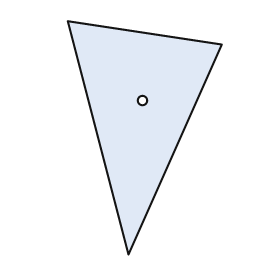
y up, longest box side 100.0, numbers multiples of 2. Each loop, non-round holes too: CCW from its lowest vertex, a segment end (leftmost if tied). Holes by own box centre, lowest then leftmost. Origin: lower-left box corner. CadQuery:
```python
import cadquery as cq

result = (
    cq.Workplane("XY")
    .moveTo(26.0, 0.0)
    .lineTo(66.0, 90.0)
    .lineTo(0.0, 100.0)
    .close()
    .moveTo(32.0, 66.0)
    .circle(2.0)
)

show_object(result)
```